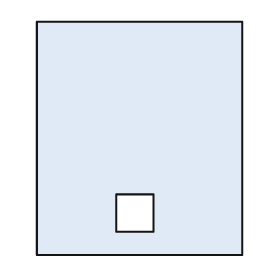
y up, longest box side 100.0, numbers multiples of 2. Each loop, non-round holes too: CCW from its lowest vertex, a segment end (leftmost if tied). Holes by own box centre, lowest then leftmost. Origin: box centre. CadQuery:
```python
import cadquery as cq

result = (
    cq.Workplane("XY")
    .moveTo(-44.0, -50.0)
    .lineTo(44.0, -50.0)
    .lineTo(44.0, 50.0)
    .lineTo(-44.0, 50.0)
    .close()
    .moveTo(-10.0, -40.0)
    .lineTo(6.0, -40.0)
    .lineTo(6.0, -24.0)
    .lineTo(-10.0, -24.0)
    .close()
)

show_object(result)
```